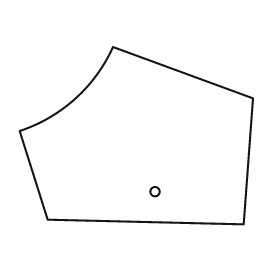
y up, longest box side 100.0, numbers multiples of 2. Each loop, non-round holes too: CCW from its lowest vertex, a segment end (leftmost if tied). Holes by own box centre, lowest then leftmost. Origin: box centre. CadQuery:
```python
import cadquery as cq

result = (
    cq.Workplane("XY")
    .moveTo(46.0, -38.0)
    .lineTo(50.0, 16.0)
    .lineTo(-10.0, 38.0)
    .threePointArc((-26.0, 16.0), (-50.0, 2.0))
    .lineTo(-38.0, -36.0)
    .close()
    .moveTo(8.0, -24.0)
    .circle(2.0)
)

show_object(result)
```